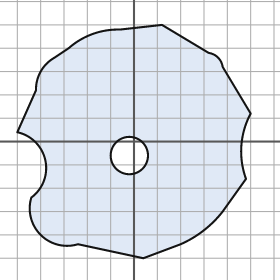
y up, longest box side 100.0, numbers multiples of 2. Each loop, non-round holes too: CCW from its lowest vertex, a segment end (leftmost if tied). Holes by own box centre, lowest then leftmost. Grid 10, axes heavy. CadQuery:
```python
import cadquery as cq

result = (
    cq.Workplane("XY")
    .moveTo(4.0, -50.0)
    .lineTo(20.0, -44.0)
    .threePointArc((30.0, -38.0), (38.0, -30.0))
    .lineTo(48.0, -16.0)
    .threePointArc((46.0, -2.0), (50.0, 12.0))
    .lineTo(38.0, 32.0)
    .threePointArc((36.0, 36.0), (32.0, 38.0))
    .lineTo(12.0, 50.0)
    .lineTo(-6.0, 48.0)
    .threePointArc((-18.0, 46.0), (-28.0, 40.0))
    .lineTo(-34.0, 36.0)
    .threePointArc((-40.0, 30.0), (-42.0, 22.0))
    .lineTo(-50.0, 4.0)
    .threePointArc((-38.0, -8.0), (-44.0, -24.0))
    .threePointArc((-40.0, -40.0), (-24.0, -44.0))
    .close()
    .moveTo(-2.0, -6.0)
    .circle(8.0)
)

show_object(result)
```